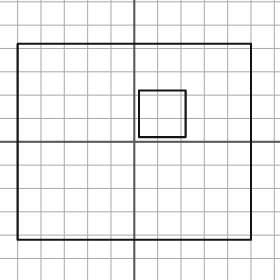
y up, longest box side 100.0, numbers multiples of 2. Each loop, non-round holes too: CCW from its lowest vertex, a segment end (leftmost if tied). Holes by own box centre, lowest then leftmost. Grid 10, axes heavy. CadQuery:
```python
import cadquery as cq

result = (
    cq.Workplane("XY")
    .moveTo(-50.0, -42.0)
    .lineTo(50.0, -42.0)
    .lineTo(50.0, 42.0)
    .lineTo(-50.0, 42.0)
    .close()
    .moveTo(2.0, 2.0)
    .lineTo(22.0, 2.0)
    .lineTo(22.0, 22.0)
    .lineTo(2.0, 22.0)
    .close()
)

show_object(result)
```